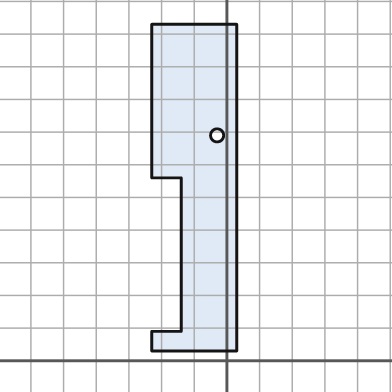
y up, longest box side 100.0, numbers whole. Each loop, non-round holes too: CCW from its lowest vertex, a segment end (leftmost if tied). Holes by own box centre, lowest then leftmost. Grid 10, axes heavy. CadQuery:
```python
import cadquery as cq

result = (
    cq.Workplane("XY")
    .moveTo(-23.0, 3.0)
    .lineTo(3.0, 3.0)
    .lineTo(3.0, 103.0)
    .lineTo(-23.0, 103.0)
    .lineTo(-23.0, 56.0)
    .lineTo(-14.0, 56.0)
    .lineTo(-14.0, 9.0)
    .lineTo(-23.0, 9.0)
    .close()
    .moveTo(-3.0, 69.0)
    .circle(2.0)
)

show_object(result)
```